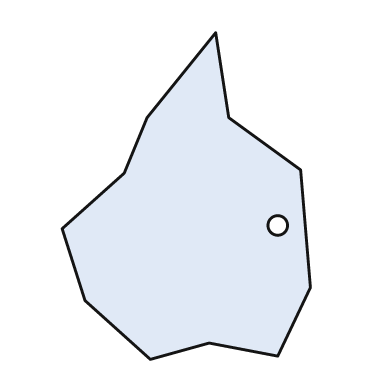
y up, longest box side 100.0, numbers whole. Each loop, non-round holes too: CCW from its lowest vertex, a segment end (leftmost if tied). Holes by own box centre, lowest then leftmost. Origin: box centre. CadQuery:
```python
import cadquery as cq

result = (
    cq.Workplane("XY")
    .moveTo(-11.0, -50.0)
    .lineTo(7.0, -45.0)
    .lineTo(28.0, -49.0)
    .lineTo(38.0, -28.0)
    .lineTo(35.0, 8.0)
    .lineTo(13.0, 24.0)
    .lineTo(9.0, 50.0)
    .lineTo(-12.0, 24.0)
    .lineTo(-19.0, 7.0)
    .lineTo(-38.0, -10.0)
    .lineTo(-31.0, -32.0)
    .close()
    .moveTo(28.0, -9.0)
    .circle(3.0)
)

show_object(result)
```